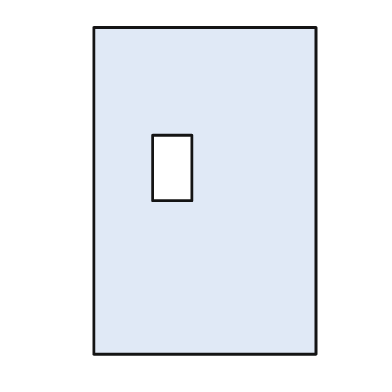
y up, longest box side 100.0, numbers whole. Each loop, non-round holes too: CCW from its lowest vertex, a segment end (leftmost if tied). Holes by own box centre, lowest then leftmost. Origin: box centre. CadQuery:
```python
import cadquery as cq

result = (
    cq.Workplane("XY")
    .moveTo(-34.0, -50.0)
    .lineTo(34.0, -50.0)
    .lineTo(34.0, 50.0)
    .lineTo(-34.0, 50.0)
    .close()
    .moveTo(-16.0, -3.0)
    .lineTo(-4.0, -3.0)
    .lineTo(-4.0, 17.0)
    .lineTo(-16.0, 17.0)
    .close()
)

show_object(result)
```